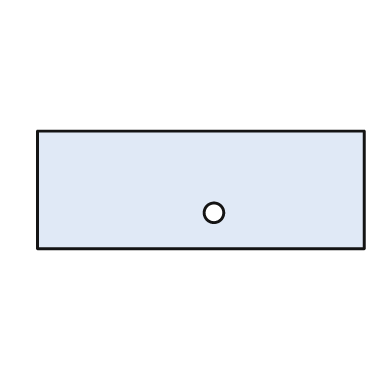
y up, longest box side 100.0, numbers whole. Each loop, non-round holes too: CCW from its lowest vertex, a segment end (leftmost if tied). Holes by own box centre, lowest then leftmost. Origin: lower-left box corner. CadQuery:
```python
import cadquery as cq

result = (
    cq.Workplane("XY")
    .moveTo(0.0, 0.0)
    .lineTo(100.0, 0.0)
    .lineTo(100.0, 36.0)
    .lineTo(0.0, 36.0)
    .close()
    .moveTo(54.0, 11.0)
    .circle(3.0)
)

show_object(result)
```